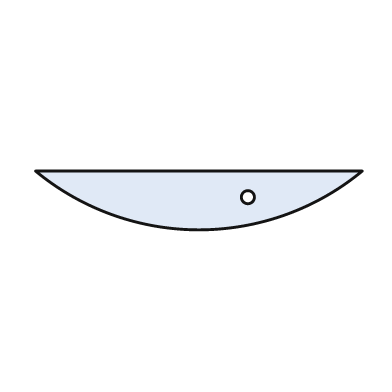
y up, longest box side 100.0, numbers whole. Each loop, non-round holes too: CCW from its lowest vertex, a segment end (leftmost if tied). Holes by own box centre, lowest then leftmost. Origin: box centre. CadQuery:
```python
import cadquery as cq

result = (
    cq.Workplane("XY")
    .moveTo(-50.0, 9.0)
    .threePointArc((0.0, -9.0), (50.0, 9.0))
    .close()
    .moveTo(15.0, 1.0)
    .circle(2.0)
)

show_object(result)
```